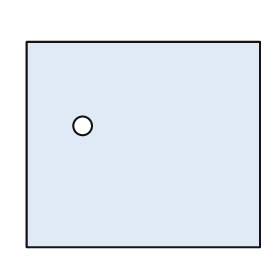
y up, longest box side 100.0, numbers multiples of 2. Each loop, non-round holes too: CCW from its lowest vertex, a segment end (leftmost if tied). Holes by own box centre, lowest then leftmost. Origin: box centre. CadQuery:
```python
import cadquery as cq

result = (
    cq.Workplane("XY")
    .moveTo(-50.0, -44.0)
    .lineTo(50.0, -44.0)
    .lineTo(50.0, 44.0)
    .lineTo(-50.0, 44.0)
    .close()
    .moveTo(-26.0, 8.0)
    .circle(4.0)
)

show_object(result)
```